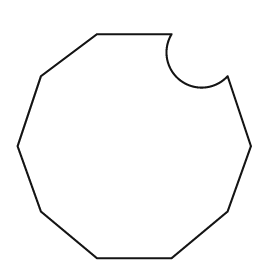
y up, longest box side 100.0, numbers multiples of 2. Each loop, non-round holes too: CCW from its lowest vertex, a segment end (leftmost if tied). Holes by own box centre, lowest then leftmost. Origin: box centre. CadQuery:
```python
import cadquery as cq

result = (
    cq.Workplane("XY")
    .moveTo(-16.0, -48.0)
    .lineTo(16.0, -48.0)
    .lineTo(40.0, -28.0)
    .lineTo(50.0, 0.0)
    .lineTo(40.0, 30.0)
    .threePointArc((20.0, 28.0), (16.0, 48.0))
    .lineTo(-16.0, 48.0)
    .lineTo(-40.0, 30.0)
    .lineTo(-50.0, 0.0)
    .lineTo(-40.0, -28.0)
    .close()
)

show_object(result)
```